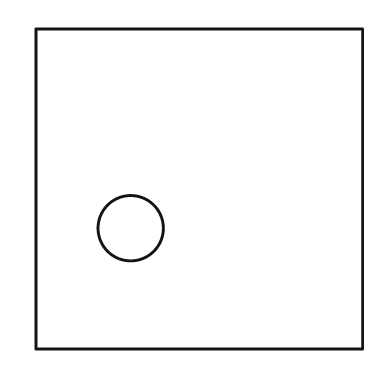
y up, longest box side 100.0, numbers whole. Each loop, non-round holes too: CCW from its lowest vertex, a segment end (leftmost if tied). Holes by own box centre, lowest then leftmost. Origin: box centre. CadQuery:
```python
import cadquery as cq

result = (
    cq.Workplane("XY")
    .moveTo(-50.0, -49.0)
    .lineTo(50.0, -49.0)
    .lineTo(50.0, 49.0)
    .lineTo(-50.0, 49.0)
    .close()
    .moveTo(-21.0, -12.0)
    .circle(10.0)
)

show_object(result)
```